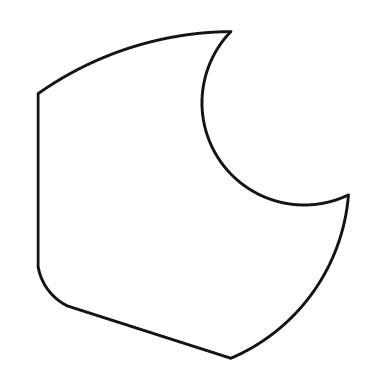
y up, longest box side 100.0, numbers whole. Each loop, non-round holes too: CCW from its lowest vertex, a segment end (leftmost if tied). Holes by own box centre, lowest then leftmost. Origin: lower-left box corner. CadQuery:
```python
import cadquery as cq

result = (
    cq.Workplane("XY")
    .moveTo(59.0, 0.0)
    .threePointArc((84.0, 20.0), (95.0, 50.0))
    .threePointArc((56.0, 60.0), (59.0, 100.0))
    .threePointArc((28.0, 95.0), (0.0, 81.0))
    .lineTo(0.0, 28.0)
    .threePointArc((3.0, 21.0), (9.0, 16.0))
    .close()
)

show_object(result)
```